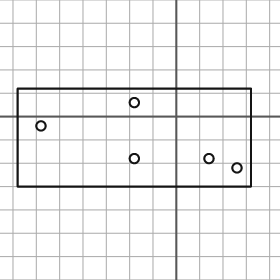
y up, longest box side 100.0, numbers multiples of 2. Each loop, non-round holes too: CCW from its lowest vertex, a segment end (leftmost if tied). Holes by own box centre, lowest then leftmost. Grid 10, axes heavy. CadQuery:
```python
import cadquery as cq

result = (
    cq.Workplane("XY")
    .moveTo(-68.0, -30.0)
    .lineTo(32.0, -30.0)
    .lineTo(32.0, 12.0)
    .lineTo(-68.0, 12.0)
    .close()
    .moveTo(26.0, -22.0)
    .circle(2.0)
    .moveTo(-18.0, -18.0)
    .circle(2.0)
    .moveTo(14.0, -18.0)
    .circle(2.0)
    .moveTo(-58.0, -4.0)
    .circle(2.0)
    .moveTo(-18.0, 6.0)
    .circle(2.0)
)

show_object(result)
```